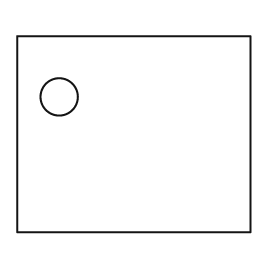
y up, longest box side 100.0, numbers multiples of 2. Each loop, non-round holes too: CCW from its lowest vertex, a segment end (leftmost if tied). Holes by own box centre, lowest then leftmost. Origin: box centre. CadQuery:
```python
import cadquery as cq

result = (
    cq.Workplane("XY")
    .moveTo(-50.0, -42.0)
    .lineTo(50.0, -42.0)
    .lineTo(50.0, 42.0)
    .lineTo(-50.0, 42.0)
    .close()
    .moveTo(-32.0, 16.0)
    .circle(8.0)
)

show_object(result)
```